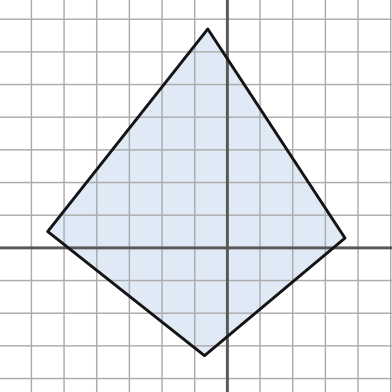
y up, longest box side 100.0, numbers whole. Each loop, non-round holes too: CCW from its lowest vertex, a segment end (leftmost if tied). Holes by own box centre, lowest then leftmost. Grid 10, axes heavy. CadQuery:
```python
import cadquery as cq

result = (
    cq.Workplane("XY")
    .moveTo(-7.0, -33.0)
    .lineTo(36.0, 3.0)
    .lineTo(-6.0, 67.0)
    .lineTo(-55.0, 5.0)
    .close()
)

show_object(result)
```